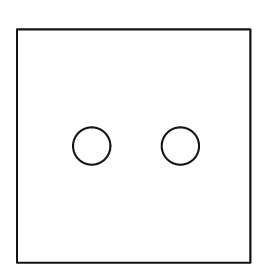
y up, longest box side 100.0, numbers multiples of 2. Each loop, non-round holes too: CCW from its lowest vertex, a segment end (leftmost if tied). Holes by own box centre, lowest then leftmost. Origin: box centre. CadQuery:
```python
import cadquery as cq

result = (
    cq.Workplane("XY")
    .moveTo(-50.0, -50.0)
    .lineTo(50.0, -50.0)
    .lineTo(50.0, 50.0)
    .lineTo(-50.0, 50.0)
    .close()
    .moveTo(-18.0, 0.0)
    .circle(8.0)
    .moveTo(20.0, 0.0)
    .circle(8.0)
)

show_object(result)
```